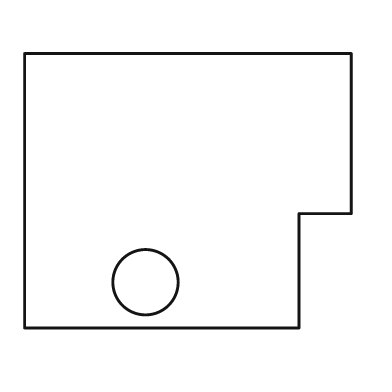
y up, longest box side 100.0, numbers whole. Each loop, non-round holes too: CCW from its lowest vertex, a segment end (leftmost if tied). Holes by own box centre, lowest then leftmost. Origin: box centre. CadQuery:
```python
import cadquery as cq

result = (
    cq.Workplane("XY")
    .moveTo(-50.0, -42.0)
    .lineTo(34.0, -42.0)
    .lineTo(34.0, -7.0)
    .lineTo(50.0, -7.0)
    .lineTo(50.0, 42.0)
    .lineTo(-50.0, 42.0)
    .close()
    .moveTo(-13.0, -28.0)
    .circle(10.0)
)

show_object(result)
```